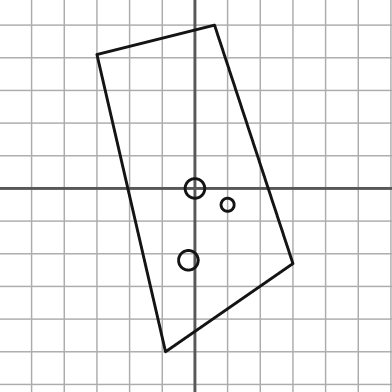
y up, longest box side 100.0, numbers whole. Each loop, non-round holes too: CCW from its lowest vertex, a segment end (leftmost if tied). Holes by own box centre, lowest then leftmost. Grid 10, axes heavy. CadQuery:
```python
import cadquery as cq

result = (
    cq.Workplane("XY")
    .moveTo(-9.0, -50.0)
    .lineTo(30.0, -23.0)
    .lineTo(6.0, 50.0)
    .lineTo(-30.0, 41.0)
    .close()
    .moveTo(-2.0, -22.0)
    .circle(3.0)
    .moveTo(10.0, -5.0)
    .circle(2.0)
    .moveTo(0.0, 0.0)
    .circle(3.0)
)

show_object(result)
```